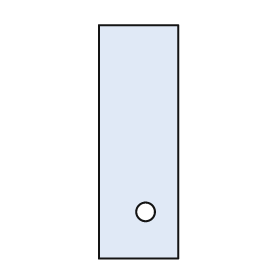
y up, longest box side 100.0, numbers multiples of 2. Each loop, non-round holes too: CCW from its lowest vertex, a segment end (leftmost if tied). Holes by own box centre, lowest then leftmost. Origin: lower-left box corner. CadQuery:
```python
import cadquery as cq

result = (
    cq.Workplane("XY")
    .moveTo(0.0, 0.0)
    .lineTo(34.0, 0.0)
    .lineTo(34.0, 100.0)
    .lineTo(0.0, 100.0)
    .close()
    .moveTo(20.0, 20.0)
    .circle(4.0)
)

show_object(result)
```